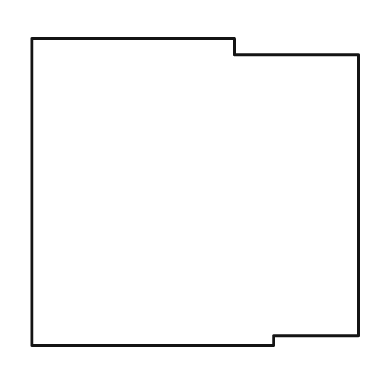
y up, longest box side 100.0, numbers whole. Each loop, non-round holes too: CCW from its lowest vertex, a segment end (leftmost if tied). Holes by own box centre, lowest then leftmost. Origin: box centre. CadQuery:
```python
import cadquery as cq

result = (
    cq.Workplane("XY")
    .moveTo(-50.0, -47.0)
    .lineTo(24.0, -47.0)
    .lineTo(24.0, -44.0)
    .lineTo(50.0, -44.0)
    .lineTo(50.0, 42.0)
    .lineTo(12.0, 42.0)
    .lineTo(12.0, 47.0)
    .lineTo(-50.0, 47.0)
    .close()
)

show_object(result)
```